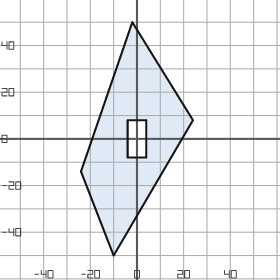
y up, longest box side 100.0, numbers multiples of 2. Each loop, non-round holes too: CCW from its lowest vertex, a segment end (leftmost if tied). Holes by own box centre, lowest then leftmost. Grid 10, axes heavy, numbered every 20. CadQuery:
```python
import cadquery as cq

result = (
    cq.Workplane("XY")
    .moveTo(-10.0, -50.0)
    .lineTo(24.0, 8.0)
    .lineTo(-2.0, 50.0)
    .lineTo(-24.0, -14.0)
    .close()
    .moveTo(-4.0, -8.0)
    .lineTo(4.0, -8.0)
    .lineTo(4.0, 8.0)
    .lineTo(-4.0, 8.0)
    .close()
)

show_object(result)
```